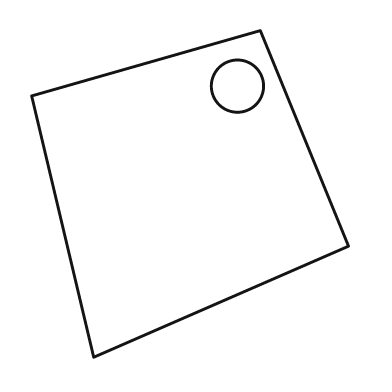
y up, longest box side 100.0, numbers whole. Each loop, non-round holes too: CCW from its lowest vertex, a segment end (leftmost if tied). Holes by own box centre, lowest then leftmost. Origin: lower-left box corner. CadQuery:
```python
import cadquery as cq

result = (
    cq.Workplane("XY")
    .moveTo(19.0, 0.0)
    .lineTo(97.0, 34.0)
    .lineTo(70.0, 100.0)
    .lineTo(0.0, 80.0)
    .close()
    .moveTo(63.0, 83.0)
    .circle(8.0)
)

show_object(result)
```